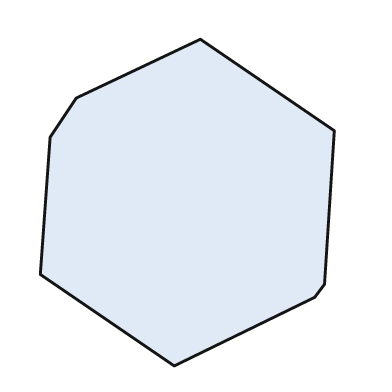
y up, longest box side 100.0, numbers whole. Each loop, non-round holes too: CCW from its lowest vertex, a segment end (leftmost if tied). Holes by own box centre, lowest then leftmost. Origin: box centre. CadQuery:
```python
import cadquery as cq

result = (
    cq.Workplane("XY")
    .moveTo(-4.0, -50.0)
    .lineTo(39.0, -29.0)
    .lineTo(42.0, -25.0)
    .lineTo(45.0, 22.0)
    .lineTo(4.0, 50.0)
    .lineTo(-34.0, 32.0)
    .lineTo(-42.0, 20.0)
    .lineTo(-45.0, -22.0)
    .close()
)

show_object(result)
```